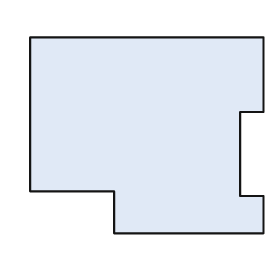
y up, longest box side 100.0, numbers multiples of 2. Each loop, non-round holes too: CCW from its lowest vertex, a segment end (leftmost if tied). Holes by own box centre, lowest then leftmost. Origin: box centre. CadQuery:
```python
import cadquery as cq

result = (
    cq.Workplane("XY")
    .moveTo(-14.0, -42.0)
    .lineTo(50.0, -42.0)
    .lineTo(50.0, -26.0)
    .lineTo(40.0, -26.0)
    .lineTo(40.0, 10.0)
    .lineTo(50.0, 10.0)
    .lineTo(50.0, 42.0)
    .lineTo(-50.0, 42.0)
    .lineTo(-50.0, -24.0)
    .lineTo(-14.0, -24.0)
    .close()
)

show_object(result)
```